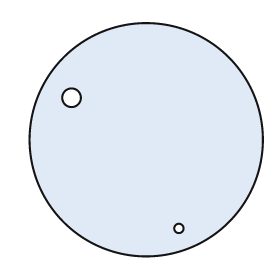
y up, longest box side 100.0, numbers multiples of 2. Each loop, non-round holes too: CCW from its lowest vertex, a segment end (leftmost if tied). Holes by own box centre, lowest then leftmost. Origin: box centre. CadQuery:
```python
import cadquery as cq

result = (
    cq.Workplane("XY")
    .moveTo(0.0, 0.0)
    .circle(50.0)
    .moveTo(14.0, -38.0)
    .circle(2.0)
    .moveTo(-32.0, 18.0)
    .circle(4.0)
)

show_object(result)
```